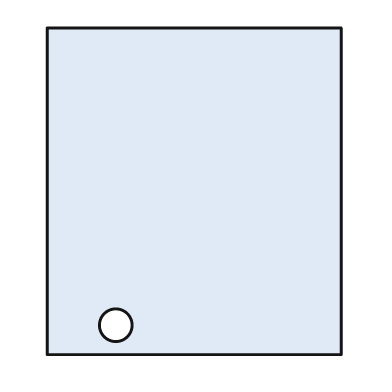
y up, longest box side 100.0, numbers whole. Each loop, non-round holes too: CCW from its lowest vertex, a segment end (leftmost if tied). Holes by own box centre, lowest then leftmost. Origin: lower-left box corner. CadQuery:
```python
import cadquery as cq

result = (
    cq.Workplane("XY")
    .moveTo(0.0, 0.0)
    .lineTo(90.0, 0.0)
    .lineTo(90.0, 100.0)
    .lineTo(0.0, 100.0)
    .close()
    .moveTo(21.0, 9.0)
    .circle(5.0)
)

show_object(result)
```